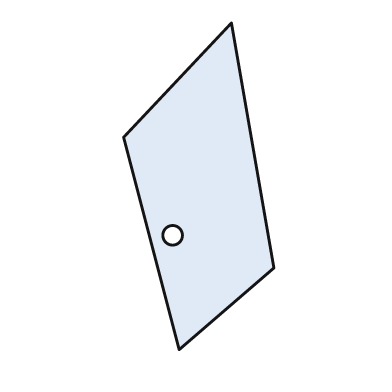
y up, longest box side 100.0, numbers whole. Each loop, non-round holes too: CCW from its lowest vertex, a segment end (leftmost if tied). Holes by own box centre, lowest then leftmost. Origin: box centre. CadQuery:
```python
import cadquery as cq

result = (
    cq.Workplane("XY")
    .moveTo(-6.0, -50.0)
    .lineTo(23.0, -25.0)
    .lineTo(10.0, 50.0)
    .lineTo(-23.0, 15.0)
    .close()
    .moveTo(-8.0, -15.0)
    .circle(3.0)
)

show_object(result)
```